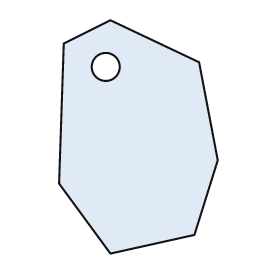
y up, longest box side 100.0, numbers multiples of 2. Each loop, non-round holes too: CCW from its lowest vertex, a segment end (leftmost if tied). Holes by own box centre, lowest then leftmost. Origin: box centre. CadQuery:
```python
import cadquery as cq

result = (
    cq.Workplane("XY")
    .moveTo(-12.0, -50.0)
    .lineTo(24.0, -42.0)
    .lineTo(34.0, -10.0)
    .lineTo(26.0, 32.0)
    .lineTo(-12.0, 50.0)
    .lineTo(-32.0, 40.0)
    .lineTo(-34.0, -20.0)
    .close()
    .moveTo(-14.0, 30.0)
    .circle(6.0)
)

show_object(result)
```